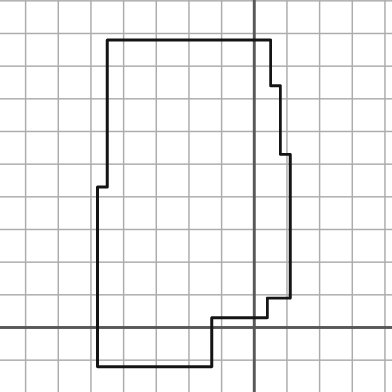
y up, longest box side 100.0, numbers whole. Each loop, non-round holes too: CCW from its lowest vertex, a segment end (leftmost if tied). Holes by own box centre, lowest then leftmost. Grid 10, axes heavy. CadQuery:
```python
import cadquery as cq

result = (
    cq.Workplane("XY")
    .moveTo(-48.0, -12.0)
    .lineTo(-13.0, -12.0)
    .lineTo(-13.0, 3.0)
    .lineTo(4.0, 3.0)
    .lineTo(4.0, 9.0)
    .lineTo(11.0, 9.0)
    .lineTo(11.0, 53.0)
    .lineTo(8.0, 53.0)
    .lineTo(8.0, 74.0)
    .lineTo(5.0, 74.0)
    .lineTo(5.0, 88.0)
    .lineTo(-45.0, 88.0)
    .lineTo(-45.0, 43.0)
    .lineTo(-48.0, 43.0)
    .close()
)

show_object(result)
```